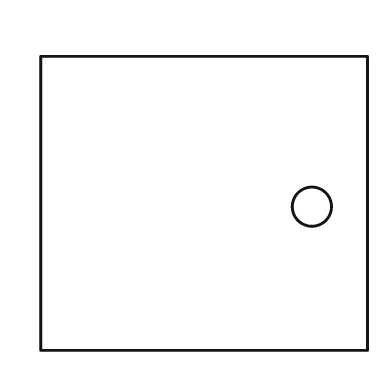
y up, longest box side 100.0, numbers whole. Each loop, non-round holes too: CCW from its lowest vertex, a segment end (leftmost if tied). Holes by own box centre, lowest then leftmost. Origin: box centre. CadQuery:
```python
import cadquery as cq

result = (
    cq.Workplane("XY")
    .moveTo(-50.0, -45.0)
    .lineTo(50.0, -45.0)
    .lineTo(50.0, 45.0)
    .lineTo(-50.0, 45.0)
    .close()
    .moveTo(33.0, -1.0)
    .circle(6.0)
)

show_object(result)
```